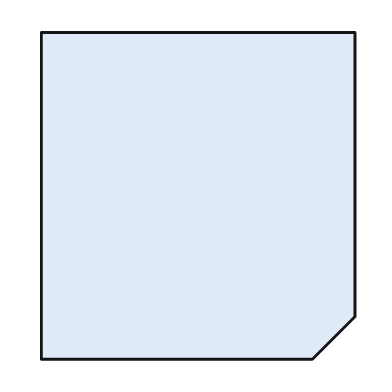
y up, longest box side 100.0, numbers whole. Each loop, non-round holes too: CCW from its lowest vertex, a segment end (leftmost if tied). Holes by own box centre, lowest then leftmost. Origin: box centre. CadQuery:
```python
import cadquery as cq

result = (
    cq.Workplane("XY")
    .moveTo(-48.0, -50.0)
    .lineTo(35.0, -50.0)
    .lineTo(48.0, -37.0)
    .lineTo(48.0, 50.0)
    .lineTo(-48.0, 50.0)
    .close()
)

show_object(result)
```